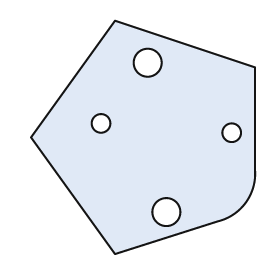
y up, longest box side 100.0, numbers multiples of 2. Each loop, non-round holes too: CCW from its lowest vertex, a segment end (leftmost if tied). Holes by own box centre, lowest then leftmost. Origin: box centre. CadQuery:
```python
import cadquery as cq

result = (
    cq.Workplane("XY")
    .moveTo(-12.0, -50.0)
    .lineTo(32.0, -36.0)
    .threePointArc((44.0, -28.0), (48.0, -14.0))
    .lineTo(48.0, 30.0)
    .lineTo(-12.0, 50.0)
    .lineTo(-48.0, 0.0)
    .close()
    .moveTo(10.0, -32.0)
    .circle(6.0)
    .moveTo(38.0, 2.0)
    .circle(4.0)
    .moveTo(-18.0, 6.0)
    .circle(4.0)
    .moveTo(2.0, 32.0)
    .circle(6.0)
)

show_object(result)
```